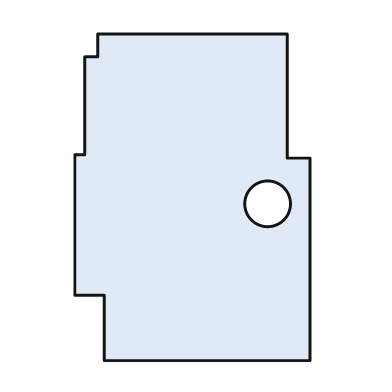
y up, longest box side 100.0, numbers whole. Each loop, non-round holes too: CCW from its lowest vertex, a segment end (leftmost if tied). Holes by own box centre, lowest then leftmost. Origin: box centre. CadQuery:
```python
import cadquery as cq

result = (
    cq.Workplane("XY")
    .moveTo(-27.0, -50.0)
    .lineTo(36.0, -50.0)
    .lineTo(36.0, 12.0)
    .lineTo(29.0, 12.0)
    .lineTo(29.0, 50.0)
    .lineTo(-29.0, 50.0)
    .lineTo(-29.0, 43.0)
    .lineTo(-33.0, 43.0)
    .lineTo(-33.0, 13.0)
    .lineTo(-36.0, 13.0)
    .lineTo(-36.0, -30.0)
    .lineTo(-27.0, -30.0)
    .close()
    .moveTo(23.0, -2.0)
    .circle(7.0)
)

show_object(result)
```